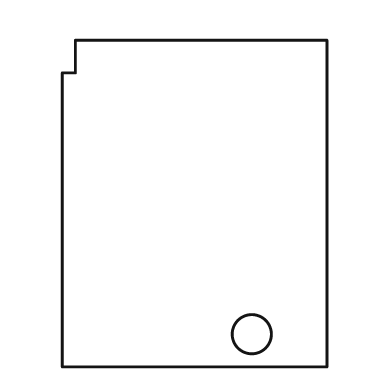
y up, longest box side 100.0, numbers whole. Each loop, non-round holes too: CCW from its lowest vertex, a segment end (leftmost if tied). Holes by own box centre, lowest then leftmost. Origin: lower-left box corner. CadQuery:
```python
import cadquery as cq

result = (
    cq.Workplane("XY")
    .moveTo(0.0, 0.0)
    .lineTo(81.0, 0.0)
    .lineTo(81.0, 100.0)
    .lineTo(4.0, 100.0)
    .lineTo(4.0, 90.0)
    .lineTo(0.0, 90.0)
    .close()
    .moveTo(58.0, 10.0)
    .circle(6.0)
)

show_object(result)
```